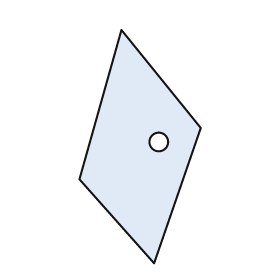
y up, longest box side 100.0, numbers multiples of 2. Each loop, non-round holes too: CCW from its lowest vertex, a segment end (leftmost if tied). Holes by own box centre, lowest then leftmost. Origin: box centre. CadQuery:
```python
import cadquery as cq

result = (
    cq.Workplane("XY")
    .moveTo(6.0, -50.0)
    .lineTo(26.0, 8.0)
    .lineTo(-8.0, 50.0)
    .lineTo(-26.0, -14.0)
    .close()
    .moveTo(8.0, 2.0)
    .circle(4.0)
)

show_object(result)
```